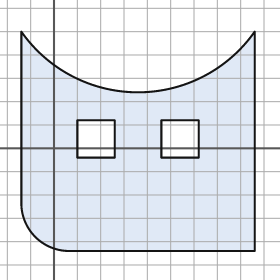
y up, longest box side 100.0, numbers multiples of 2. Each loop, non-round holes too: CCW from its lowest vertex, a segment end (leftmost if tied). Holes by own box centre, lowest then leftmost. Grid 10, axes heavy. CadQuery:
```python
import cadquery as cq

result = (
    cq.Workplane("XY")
    .moveTo(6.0, -44.0)
    .lineTo(86.0, -44.0)
    .lineTo(86.0, 50.0)
    .threePointArc((36.0, 24.0), (-14.0, 50.0))
    .lineTo(-14.0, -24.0)
    .threePointArc((-8.0, -38.0), (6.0, -44.0))
    .close()
    .moveTo(10.0, -4.0)
    .lineTo(26.0, -4.0)
    .lineTo(26.0, 12.0)
    .lineTo(10.0, 12.0)
    .close()
    .moveTo(46.0, -4.0)
    .lineTo(62.0, -4.0)
    .lineTo(62.0, 12.0)
    .lineTo(46.0, 12.0)
    .close()
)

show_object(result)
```